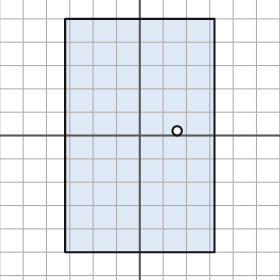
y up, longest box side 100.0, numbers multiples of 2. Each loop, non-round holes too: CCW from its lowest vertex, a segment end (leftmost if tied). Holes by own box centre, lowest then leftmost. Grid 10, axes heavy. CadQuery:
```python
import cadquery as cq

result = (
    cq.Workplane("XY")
    .moveTo(-32.0, -50.0)
    .lineTo(32.0, -50.0)
    .lineTo(32.0, 50.0)
    .lineTo(-32.0, 50.0)
    .close()
    .moveTo(16.0, 2.0)
    .circle(2.0)
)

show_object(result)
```